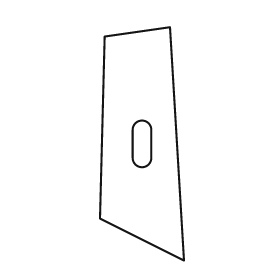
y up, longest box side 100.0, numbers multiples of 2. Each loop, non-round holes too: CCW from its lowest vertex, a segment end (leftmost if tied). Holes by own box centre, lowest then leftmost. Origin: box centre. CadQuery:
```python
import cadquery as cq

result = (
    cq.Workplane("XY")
    .moveTo(18.0, -50.0)
    .lineTo(12.0, 50.0)
    .lineTo(-16.0, 46.0)
    .lineTo(-18.0, -32.0)
    .close()
    .moveTo(-4.0, -6.0)
    .threePointArc((0.0, -10.0), (4.0, -6.0))
    .lineTo(4.0, 6.0)
    .threePointArc((0.0, 10.0), (-4.0, 6.0))
    .close()
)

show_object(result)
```